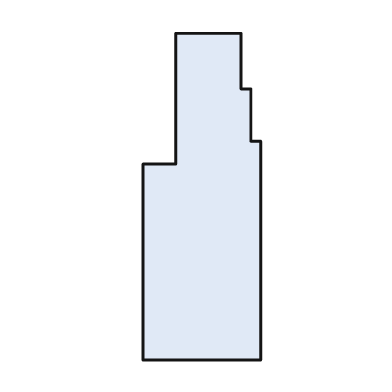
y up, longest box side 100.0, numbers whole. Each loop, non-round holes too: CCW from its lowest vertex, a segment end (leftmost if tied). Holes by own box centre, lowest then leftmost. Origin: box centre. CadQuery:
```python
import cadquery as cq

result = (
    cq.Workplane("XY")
    .moveTo(-18.0, -50.0)
    .lineTo(18.0, -50.0)
    .lineTo(18.0, 17.0)
    .lineTo(15.0, 17.0)
    .lineTo(15.0, 33.0)
    .lineTo(12.0, 33.0)
    .lineTo(12.0, 50.0)
    .lineTo(-8.0, 50.0)
    .lineTo(-8.0, 10.0)
    .lineTo(-18.0, 10.0)
    .close()
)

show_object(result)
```